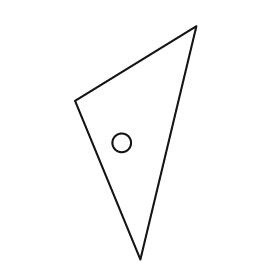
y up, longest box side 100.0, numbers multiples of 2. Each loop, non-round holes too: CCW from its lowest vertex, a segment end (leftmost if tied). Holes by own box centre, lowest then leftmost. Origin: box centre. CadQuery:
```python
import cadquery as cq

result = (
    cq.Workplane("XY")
    .moveTo(2.0, -50.0)
    .lineTo(26.0, 50.0)
    .lineTo(-26.0, 18.0)
    .close()
    .moveTo(-6.0, 0.0)
    .circle(4.0)
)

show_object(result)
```